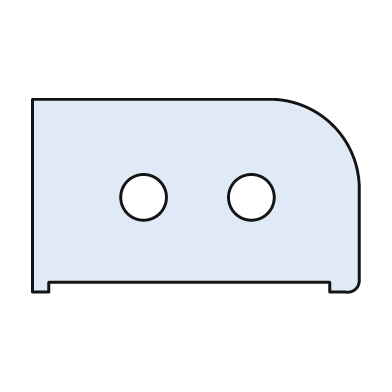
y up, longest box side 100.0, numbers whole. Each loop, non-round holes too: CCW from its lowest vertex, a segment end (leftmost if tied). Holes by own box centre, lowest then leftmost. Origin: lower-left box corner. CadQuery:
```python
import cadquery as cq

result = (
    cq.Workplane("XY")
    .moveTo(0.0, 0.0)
    .lineTo(5.0, 0.0)
    .lineTo(5.0, 3.0)
    .lineTo(91.0, 3.0)
    .lineTo(91.0, 0.0)
    .lineTo(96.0, 0.0)
    .threePointArc((99.0, 1.0), (100.0, 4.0))
    .lineTo(100.0, 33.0)
    .threePointArc((92.0, 51.0), (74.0, 59.0))
    .lineTo(0.0, 59.0)
    .close()
    .moveTo(34.0, 29.0)
    .circle(7.0)
    .moveTo(67.0, 29.0)
    .circle(7.0)
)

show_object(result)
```